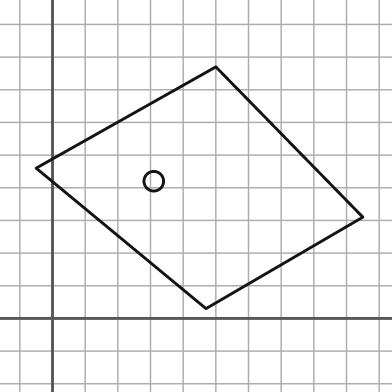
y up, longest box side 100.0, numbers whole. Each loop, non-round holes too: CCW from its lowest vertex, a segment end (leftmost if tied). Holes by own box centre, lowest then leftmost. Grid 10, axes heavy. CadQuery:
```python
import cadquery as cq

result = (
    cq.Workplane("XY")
    .moveTo(47.0, 3.0)
    .lineTo(95.0, 31.0)
    .lineTo(50.0, 77.0)
    .lineTo(-5.0, 46.0)
    .close()
    .moveTo(31.0, 42.0)
    .circle(3.0)
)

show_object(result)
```